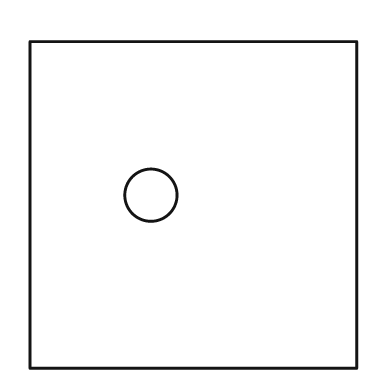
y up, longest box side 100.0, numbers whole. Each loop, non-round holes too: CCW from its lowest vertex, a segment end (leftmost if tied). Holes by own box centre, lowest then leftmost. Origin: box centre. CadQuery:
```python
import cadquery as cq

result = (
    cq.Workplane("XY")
    .moveTo(-50.0, -50.0)
    .lineTo(50.0, -50.0)
    .lineTo(50.0, 50.0)
    .lineTo(-50.0, 50.0)
    .close()
    .moveTo(-13.0, 3.0)
    .circle(8.0)
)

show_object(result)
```